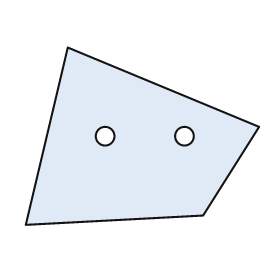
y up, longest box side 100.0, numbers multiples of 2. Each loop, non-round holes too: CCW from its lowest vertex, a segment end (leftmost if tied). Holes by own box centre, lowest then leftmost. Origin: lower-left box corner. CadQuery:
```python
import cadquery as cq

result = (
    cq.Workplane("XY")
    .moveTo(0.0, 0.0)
    .lineTo(76.0, 4.0)
    .lineTo(100.0, 42.0)
    .lineTo(18.0, 76.0)
    .close()
    .moveTo(34.0, 38.0)
    .circle(4.0)
    .moveTo(68.0, 38.0)
    .circle(4.0)
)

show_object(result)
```